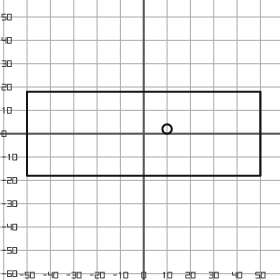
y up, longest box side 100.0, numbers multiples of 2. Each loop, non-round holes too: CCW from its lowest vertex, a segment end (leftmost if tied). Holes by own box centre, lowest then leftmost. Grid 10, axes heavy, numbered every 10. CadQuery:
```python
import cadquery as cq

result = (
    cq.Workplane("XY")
    .moveTo(-50.0, -18.0)
    .lineTo(50.0, -18.0)
    .lineTo(50.0, 18.0)
    .lineTo(-50.0, 18.0)
    .close()
    .moveTo(10.0, 2.0)
    .circle(2.0)
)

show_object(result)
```